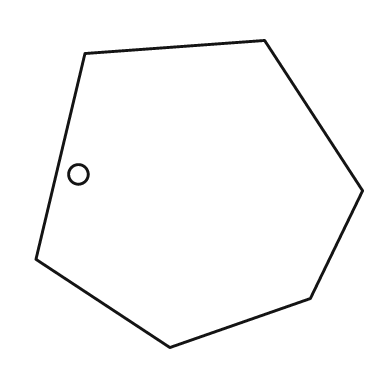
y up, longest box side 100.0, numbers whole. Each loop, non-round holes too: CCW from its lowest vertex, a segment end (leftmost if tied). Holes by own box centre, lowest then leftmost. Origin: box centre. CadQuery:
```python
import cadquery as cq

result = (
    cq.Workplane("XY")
    .moveTo(-9.0, -47.0)
    .lineTo(34.0, -32.0)
    .lineTo(50.0, 1.0)
    .lineTo(20.0, 47.0)
    .lineTo(-35.0, 43.0)
    .lineTo(-50.0, -20.0)
    .close()
    .moveTo(-37.0, 6.0)
    .circle(3.0)
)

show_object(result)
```